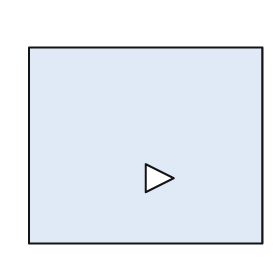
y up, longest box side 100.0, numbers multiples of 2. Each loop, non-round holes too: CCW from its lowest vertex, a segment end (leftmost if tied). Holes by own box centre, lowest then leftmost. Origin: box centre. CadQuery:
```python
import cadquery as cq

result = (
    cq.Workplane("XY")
    .moveTo(-50.0, -42.0)
    .lineTo(50.0, -42.0)
    .lineTo(50.0, 42.0)
    .lineTo(-50.0, 42.0)
    .close()
    .moveTo(0.0, -20.0)
    .lineTo(12.0, -14.0)
    .lineTo(0.0, -8.0)
    .close()
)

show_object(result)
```